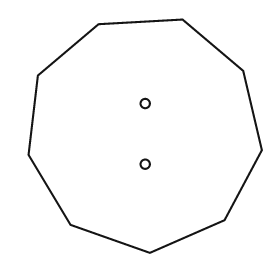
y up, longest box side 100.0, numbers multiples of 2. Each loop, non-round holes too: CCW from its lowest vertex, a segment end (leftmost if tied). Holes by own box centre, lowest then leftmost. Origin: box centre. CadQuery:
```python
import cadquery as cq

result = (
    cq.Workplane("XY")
    .moveTo(2.0, -50.0)
    .lineTo(34.0, -36.0)
    .lineTo(50.0, -6.0)
    .lineTo(42.0, 28.0)
    .lineTo(16.0, 50.0)
    .lineTo(-20.0, 48.0)
    .lineTo(-46.0, 26.0)
    .lineTo(-50.0, -8.0)
    .lineTo(-32.0, -38.0)
    .close()
    .moveTo(0.0, -12.0)
    .circle(2.0)
    .moveTo(0.0, 14.0)
    .circle(2.0)
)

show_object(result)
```